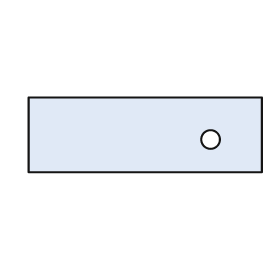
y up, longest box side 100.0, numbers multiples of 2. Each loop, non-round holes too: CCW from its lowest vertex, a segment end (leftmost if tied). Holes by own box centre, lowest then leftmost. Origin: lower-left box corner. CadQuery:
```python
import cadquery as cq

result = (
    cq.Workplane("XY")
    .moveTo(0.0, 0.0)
    .lineTo(100.0, 0.0)
    .lineTo(100.0, 32.0)
    .lineTo(0.0, 32.0)
    .close()
    .moveTo(78.0, 14.0)
    .circle(4.0)
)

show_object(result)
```